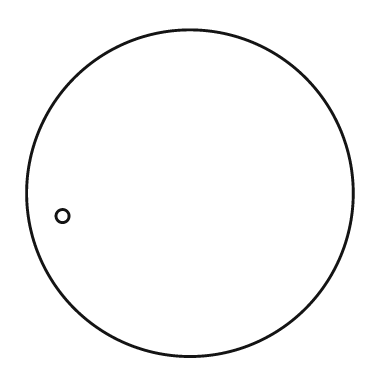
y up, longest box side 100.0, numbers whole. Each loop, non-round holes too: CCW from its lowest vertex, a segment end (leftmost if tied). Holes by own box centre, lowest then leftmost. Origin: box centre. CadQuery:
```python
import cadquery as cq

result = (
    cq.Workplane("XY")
    .moveTo(0.0, 0.0)
    .circle(50.0)
    .moveTo(-39.0, -7.0)
    .circle(2.0)
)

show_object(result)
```